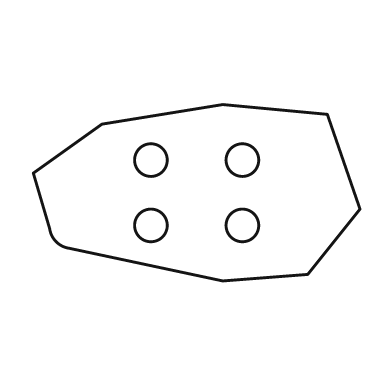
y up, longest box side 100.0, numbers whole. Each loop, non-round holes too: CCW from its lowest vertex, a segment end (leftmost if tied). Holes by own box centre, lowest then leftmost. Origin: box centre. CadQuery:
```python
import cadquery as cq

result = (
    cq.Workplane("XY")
    .moveTo(8.0, -27.0)
    .lineTo(34.0, -25.0)
    .lineTo(50.0, -5.0)
    .lineTo(40.0, 24.0)
    .lineTo(8.0, 27.0)
    .lineTo(-29.0, 21.0)
    .lineTo(-50.0, 6.0)
    .lineTo(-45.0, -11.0)
    .threePointArc((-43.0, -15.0), (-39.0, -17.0))
    .close()
    .moveTo(-14.0, -10.0)
    .circle(5.0)
    .moveTo(14.0, -10.0)
    .circle(5.0)
    .moveTo(-14.0, 10.0)
    .circle(5.0)
    .moveTo(14.0, 10.0)
    .circle(5.0)
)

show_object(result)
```